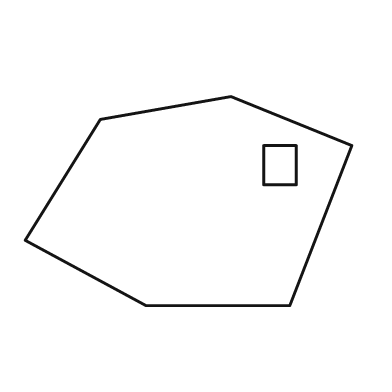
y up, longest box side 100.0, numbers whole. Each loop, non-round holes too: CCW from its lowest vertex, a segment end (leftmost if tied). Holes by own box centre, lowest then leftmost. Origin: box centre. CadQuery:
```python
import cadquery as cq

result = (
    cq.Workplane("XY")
    .moveTo(-13.0, -32.0)
    .lineTo(31.0, -32.0)
    .lineTo(50.0, 17.0)
    .lineTo(13.0, 32.0)
    .lineTo(-27.0, 25.0)
    .lineTo(-50.0, -12.0)
    .close()
    .moveTo(23.0, 5.0)
    .lineTo(33.0, 5.0)
    .lineTo(33.0, 17.0)
    .lineTo(23.0, 17.0)
    .close()
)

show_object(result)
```